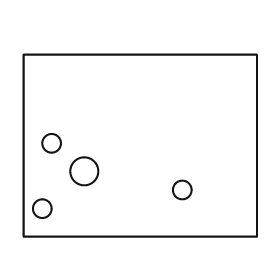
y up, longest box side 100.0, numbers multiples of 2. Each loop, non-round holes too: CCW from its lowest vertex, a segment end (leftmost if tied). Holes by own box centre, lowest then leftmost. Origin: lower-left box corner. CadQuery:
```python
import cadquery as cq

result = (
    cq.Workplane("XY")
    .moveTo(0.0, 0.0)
    .lineTo(100.0, 0.0)
    .lineTo(100.0, 78.0)
    .lineTo(0.0, 78.0)
    .close()
    .moveTo(8.0, 12.0)
    .circle(4.0)
    .moveTo(68.0, 20.0)
    .circle(4.0)
    .moveTo(26.0, 28.0)
    .circle(6.0)
    .moveTo(12.0, 40.0)
    .circle(4.0)
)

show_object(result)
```